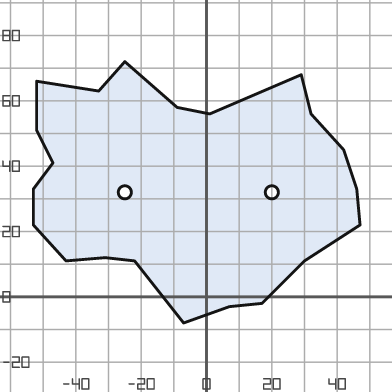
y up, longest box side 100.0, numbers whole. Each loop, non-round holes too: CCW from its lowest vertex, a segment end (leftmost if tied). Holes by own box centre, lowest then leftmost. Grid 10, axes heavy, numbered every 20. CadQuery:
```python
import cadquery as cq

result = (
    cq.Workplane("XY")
    .moveTo(-7.0, -8.0)
    .lineTo(7.0, -3.0)
    .lineTo(17.0, -2.0)
    .lineTo(30.0, 11.0)
    .lineTo(47.0, 22.0)
    .lineTo(46.0, 33.0)
    .lineTo(42.0, 45.0)
    .lineTo(32.0, 56.0)
    .lineTo(29.0, 68.0)
    .lineTo(1.0, 56.0)
    .lineTo(-9.0, 58.0)
    .lineTo(-25.0, 72.0)
    .lineTo(-33.0, 63.0)
    .lineTo(-52.0, 66.0)
    .lineTo(-52.0, 51.0)
    .lineTo(-47.0, 41.0)
    .lineTo(-53.0, 33.0)
    .lineTo(-53.0, 22.0)
    .lineTo(-43.0, 11.0)
    .lineTo(-31.0, 12.0)
    .lineTo(-22.0, 11.0)
    .close()
    .moveTo(-25.0, 32.0)
    .circle(2.0)
    .moveTo(20.0, 32.0)
    .circle(2.0)
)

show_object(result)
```